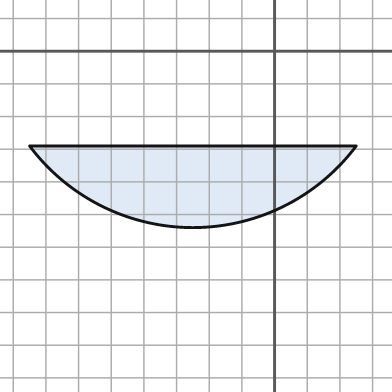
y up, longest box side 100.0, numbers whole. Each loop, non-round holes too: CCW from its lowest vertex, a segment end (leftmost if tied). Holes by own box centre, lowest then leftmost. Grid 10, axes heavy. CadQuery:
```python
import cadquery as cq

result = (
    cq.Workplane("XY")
    .moveTo(-75.0, -29.0)
    .threePointArc((-25.0, -54.0), (25.0, -29.0))
    .close()
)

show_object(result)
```